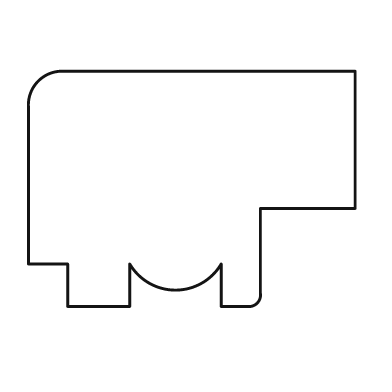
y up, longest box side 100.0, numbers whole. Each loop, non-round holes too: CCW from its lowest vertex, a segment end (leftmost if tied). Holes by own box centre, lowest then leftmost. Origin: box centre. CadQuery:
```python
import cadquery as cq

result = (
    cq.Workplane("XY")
    .moveTo(-38.0, -36.0)
    .lineTo(-19.0, -36.0)
    .lineTo(-19.0, -23.0)
    .threePointArc((-5.0, -31.0), (9.0, -23.0))
    .lineTo(9.0, -36.0)
    .lineTo(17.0, -36.0)
    .threePointArc((20.0, -35.0), (21.0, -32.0))
    .lineTo(21.0, -6.0)
    .lineTo(50.0, -6.0)
    .lineTo(50.0, 36.0)
    .lineTo(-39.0, 36.0)
    .threePointArc((-47.0, 33.0), (-50.0, 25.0))
    .lineTo(-50.0, -23.0)
    .lineTo(-38.0, -23.0)
    .close()
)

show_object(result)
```